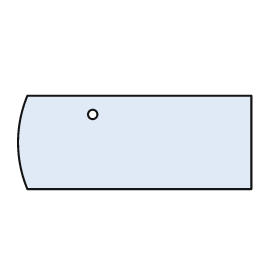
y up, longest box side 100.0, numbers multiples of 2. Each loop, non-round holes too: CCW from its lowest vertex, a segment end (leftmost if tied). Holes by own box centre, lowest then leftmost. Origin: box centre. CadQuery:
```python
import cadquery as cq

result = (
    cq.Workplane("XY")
    .moveTo(-46.0, -20.0)
    .lineTo(50.0, -20.0)
    .lineTo(50.0, 20.0)
    .lineTo(-46.0, 20.0)
    .threePointArc((-50.0, 0.0), (-46.0, -20.0))
    .close()
    .moveTo(-18.0, 12.0)
    .circle(2.0)
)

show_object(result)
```